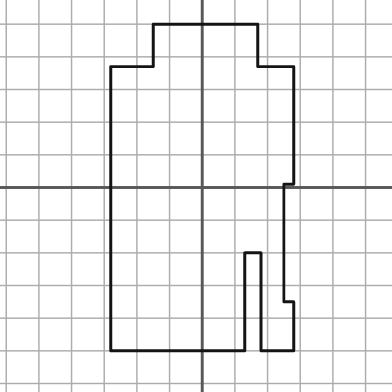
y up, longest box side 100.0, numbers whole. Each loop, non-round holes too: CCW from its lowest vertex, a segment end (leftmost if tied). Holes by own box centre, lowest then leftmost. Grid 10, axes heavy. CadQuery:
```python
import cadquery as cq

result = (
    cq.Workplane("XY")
    .moveTo(-28.0, -50.0)
    .lineTo(13.0, -50.0)
    .lineTo(13.0, -20.0)
    .lineTo(18.0, -20.0)
    .lineTo(18.0, -50.0)
    .lineTo(28.0, -50.0)
    .lineTo(28.0, -35.0)
    .lineTo(25.0, -35.0)
    .lineTo(25.0, 1.0)
    .lineTo(28.0, 1.0)
    .lineTo(28.0, 37.0)
    .lineTo(17.0, 37.0)
    .lineTo(17.0, 50.0)
    .lineTo(-15.0, 50.0)
    .lineTo(-15.0, 37.0)
    .lineTo(-28.0, 37.0)
    .close()
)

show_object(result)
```